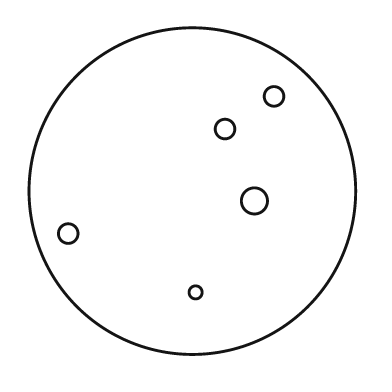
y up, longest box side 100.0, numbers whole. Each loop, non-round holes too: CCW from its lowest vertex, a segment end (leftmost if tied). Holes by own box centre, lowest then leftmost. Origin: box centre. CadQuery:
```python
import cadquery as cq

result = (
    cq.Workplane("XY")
    .moveTo(0.0, 0.0)
    .circle(50.0)
    .moveTo(1.0, -31.0)
    .circle(2.0)
    .moveTo(-38.0, -13.0)
    .circle(3.0)
    .moveTo(19.0, -3.0)
    .circle(4.0)
    .moveTo(10.0, 19.0)
    .circle(3.0)
    .moveTo(25.0, 29.0)
    .circle(3.0)
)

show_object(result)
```